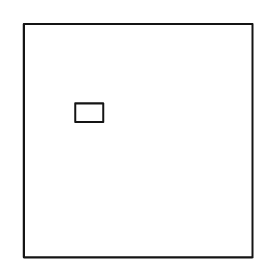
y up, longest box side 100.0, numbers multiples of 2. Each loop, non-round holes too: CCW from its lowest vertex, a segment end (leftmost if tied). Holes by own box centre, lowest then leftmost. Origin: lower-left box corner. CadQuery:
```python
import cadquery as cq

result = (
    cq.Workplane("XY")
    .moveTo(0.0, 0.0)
    .lineTo(98.0, 0.0)
    .lineTo(98.0, 100.0)
    .lineTo(0.0, 100.0)
    .close()
    .moveTo(22.0, 58.0)
    .lineTo(34.0, 58.0)
    .lineTo(34.0, 66.0)
    .lineTo(22.0, 66.0)
    .close()
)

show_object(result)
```